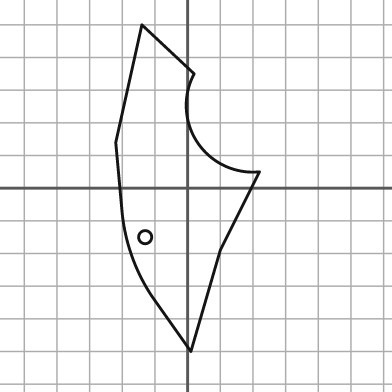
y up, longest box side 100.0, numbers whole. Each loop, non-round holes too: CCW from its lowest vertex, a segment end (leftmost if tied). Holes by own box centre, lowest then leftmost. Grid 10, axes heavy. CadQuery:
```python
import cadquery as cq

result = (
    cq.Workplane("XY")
    .moveTo(1.0, -50.0)
    .lineTo(10.0, -19.0)
    .lineTo(22.0, 5.0)
    .threePointArc((3.0, 14.0), (2.0, 35.0))
    .lineTo(-14.0, 50.0)
    .lineTo(-22.0, 14.0)
    .lineTo(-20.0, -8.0)
    .threePointArc((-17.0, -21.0), (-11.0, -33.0))
    .close()
    .moveTo(-13.0, -15.0)
    .circle(2.0)
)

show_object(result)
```